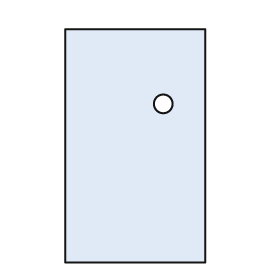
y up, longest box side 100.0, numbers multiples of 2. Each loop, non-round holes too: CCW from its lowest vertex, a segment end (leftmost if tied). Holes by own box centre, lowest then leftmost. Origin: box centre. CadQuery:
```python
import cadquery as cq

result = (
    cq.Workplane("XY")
    .moveTo(-30.0, -50.0)
    .lineTo(30.0, -50.0)
    .lineTo(30.0, 50.0)
    .lineTo(-30.0, 50.0)
    .close()
    .moveTo(12.0, 18.0)
    .circle(4.0)
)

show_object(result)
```